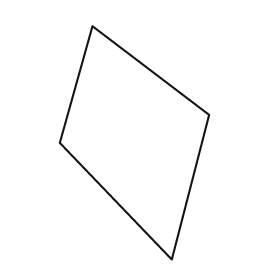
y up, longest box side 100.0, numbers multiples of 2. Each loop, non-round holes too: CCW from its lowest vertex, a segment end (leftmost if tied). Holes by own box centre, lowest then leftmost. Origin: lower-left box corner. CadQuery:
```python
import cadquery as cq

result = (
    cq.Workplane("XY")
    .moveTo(48.0, 0.0)
    .lineTo(64.0, 62.0)
    .lineTo(14.0, 100.0)
    .lineTo(0.0, 50.0)
    .close()
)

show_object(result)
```